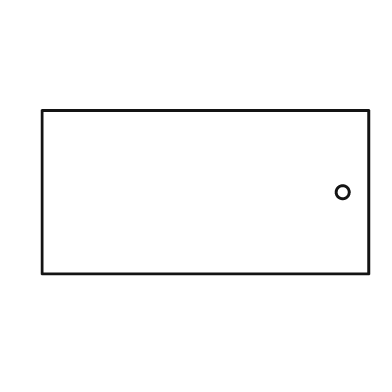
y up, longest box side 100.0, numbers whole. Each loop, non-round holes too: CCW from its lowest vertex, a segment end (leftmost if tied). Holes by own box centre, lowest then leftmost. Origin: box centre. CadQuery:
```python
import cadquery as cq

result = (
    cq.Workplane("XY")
    .moveTo(-50.0, -25.0)
    .lineTo(50.0, -25.0)
    .lineTo(50.0, 25.0)
    .lineTo(-50.0, 25.0)
    .close()
    .moveTo(42.0, 0.0)
    .circle(2.0)
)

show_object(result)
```